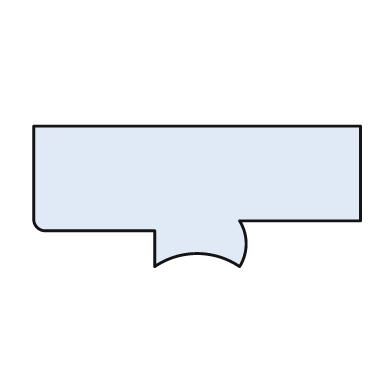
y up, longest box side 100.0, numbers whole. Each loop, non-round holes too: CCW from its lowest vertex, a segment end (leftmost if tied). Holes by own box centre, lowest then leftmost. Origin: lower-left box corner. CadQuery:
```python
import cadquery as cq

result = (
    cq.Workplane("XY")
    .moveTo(37.0, 0.0)
    .threePointArc((50.0, 4.0), (63.0, 0.0))
    .threePointArc((65.0, 7.0), (63.0, 14.0))
    .lineTo(100.0, 14.0)
    .lineTo(100.0, 43.0)
    .lineTo(0.0, 43.0)
    .lineTo(0.0, 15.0)
    .threePointArc((1.0, 12.0), (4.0, 11.0))
    .lineTo(37.0, 11.0)
    .close()
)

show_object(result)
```